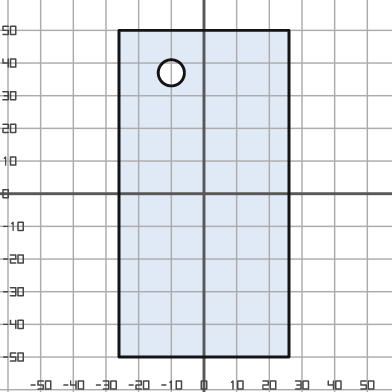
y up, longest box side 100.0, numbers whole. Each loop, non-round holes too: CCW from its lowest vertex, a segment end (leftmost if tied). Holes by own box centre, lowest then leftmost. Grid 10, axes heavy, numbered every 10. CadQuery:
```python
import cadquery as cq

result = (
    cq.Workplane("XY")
    .moveTo(-26.0, -50.0)
    .lineTo(26.0, -50.0)
    .lineTo(26.0, 50.0)
    .lineTo(-26.0, 50.0)
    .close()
    .moveTo(-10.0, 37.0)
    .circle(4.0)
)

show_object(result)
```